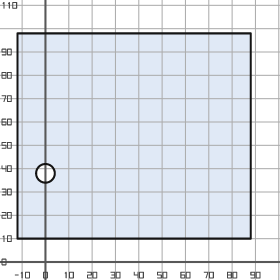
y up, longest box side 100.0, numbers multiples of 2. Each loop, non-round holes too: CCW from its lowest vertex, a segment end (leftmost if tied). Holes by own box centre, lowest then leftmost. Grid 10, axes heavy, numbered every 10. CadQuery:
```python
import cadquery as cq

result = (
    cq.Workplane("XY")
    .moveTo(-12.0, 10.0)
    .lineTo(88.0, 10.0)
    .lineTo(88.0, 98.0)
    .lineTo(-12.0, 98.0)
    .close()
    .moveTo(0.0, 38.0)
    .circle(4.0)
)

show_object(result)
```